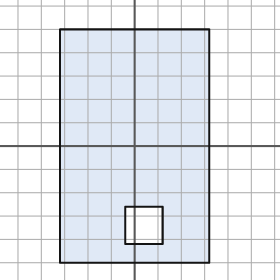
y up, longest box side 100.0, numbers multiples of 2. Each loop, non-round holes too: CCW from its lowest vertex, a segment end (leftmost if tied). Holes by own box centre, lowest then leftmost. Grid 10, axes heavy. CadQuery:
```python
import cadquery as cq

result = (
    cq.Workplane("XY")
    .moveTo(-32.0, -50.0)
    .lineTo(32.0, -50.0)
    .lineTo(32.0, 50.0)
    .lineTo(-32.0, 50.0)
    .close()
    .moveTo(-4.0, -42.0)
    .lineTo(12.0, -42.0)
    .lineTo(12.0, -26.0)
    .lineTo(-4.0, -26.0)
    .close()
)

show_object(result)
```